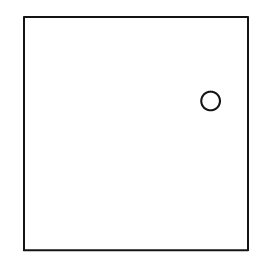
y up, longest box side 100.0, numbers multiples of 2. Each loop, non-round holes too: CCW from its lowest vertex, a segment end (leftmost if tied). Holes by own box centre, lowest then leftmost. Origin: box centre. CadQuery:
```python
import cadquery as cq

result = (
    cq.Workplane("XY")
    .moveTo(-48.0, -50.0)
    .lineTo(48.0, -50.0)
    .lineTo(48.0, 50.0)
    .lineTo(-48.0, 50.0)
    .close()
    .moveTo(32.0, 14.0)
    .circle(4.0)
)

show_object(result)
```